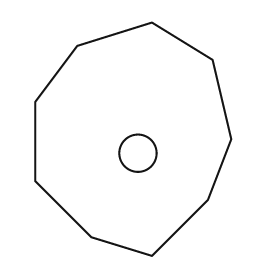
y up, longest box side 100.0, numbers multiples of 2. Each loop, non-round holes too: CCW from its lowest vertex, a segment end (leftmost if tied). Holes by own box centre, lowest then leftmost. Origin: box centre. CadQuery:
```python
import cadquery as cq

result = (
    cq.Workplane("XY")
    .moveTo(8.0, -50.0)
    .lineTo(32.0, -26.0)
    .lineTo(42.0, 0.0)
    .lineTo(34.0, 34.0)
    .lineTo(8.0, 50.0)
    .lineTo(-24.0, 40.0)
    .lineTo(-42.0, 16.0)
    .lineTo(-42.0, -18.0)
    .lineTo(-18.0, -42.0)
    .close()
    .moveTo(2.0, -6.0)
    .circle(8.0)
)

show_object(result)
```